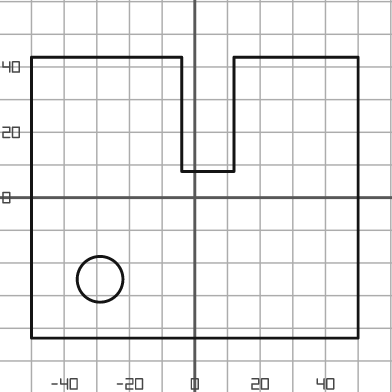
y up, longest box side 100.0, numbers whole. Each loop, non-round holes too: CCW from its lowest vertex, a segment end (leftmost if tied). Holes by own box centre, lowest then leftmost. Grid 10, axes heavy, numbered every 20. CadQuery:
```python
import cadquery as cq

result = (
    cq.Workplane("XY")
    .moveTo(-50.0, -43.0)
    .lineTo(50.0, -43.0)
    .lineTo(50.0, 43.0)
    .lineTo(12.0, 43.0)
    .lineTo(12.0, 8.0)
    .lineTo(-4.0, 8.0)
    .lineTo(-4.0, 43.0)
    .lineTo(-50.0, 43.0)
    .close()
    .moveTo(-29.0, -25.0)
    .circle(7.0)
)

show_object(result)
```